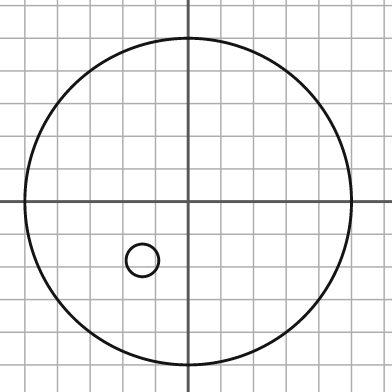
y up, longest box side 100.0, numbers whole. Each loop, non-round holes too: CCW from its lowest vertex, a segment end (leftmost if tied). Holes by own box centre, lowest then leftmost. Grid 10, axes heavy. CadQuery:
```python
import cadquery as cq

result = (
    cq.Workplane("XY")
    .moveTo(0.0, 0.0)
    .circle(50.0)
    .moveTo(-14.0, -18.0)
    .circle(5.0)
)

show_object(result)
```